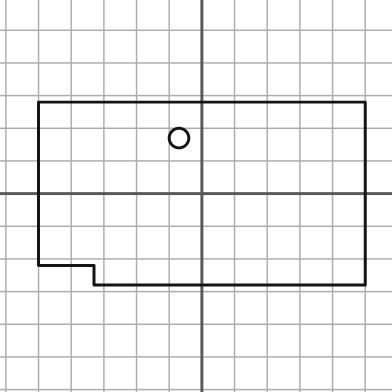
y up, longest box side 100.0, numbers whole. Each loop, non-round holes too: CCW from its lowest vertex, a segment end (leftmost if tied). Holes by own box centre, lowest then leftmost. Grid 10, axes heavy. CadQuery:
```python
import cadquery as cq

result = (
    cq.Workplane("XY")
    .moveTo(-33.0, -28.0)
    .lineTo(50.0, -28.0)
    .lineTo(50.0, 28.0)
    .lineTo(-50.0, 28.0)
    .lineTo(-50.0, -22.0)
    .lineTo(-33.0, -22.0)
    .close()
    .moveTo(-7.0, 17.0)
    .circle(3.0)
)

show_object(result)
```